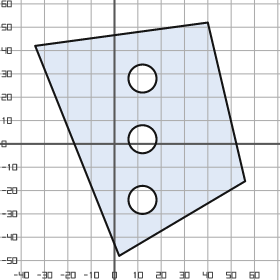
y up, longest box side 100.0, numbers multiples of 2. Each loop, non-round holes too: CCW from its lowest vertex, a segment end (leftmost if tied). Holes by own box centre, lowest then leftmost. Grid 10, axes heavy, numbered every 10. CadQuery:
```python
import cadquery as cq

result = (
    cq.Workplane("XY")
    .moveTo(2.0, -48.0)
    .lineTo(56.0, -16.0)
    .lineTo(40.0, 52.0)
    .lineTo(-34.0, 42.0)
    .close()
    .moveTo(12.0, -24.0)
    .circle(6.0)
    .moveTo(12.0, 2.0)
    .circle(6.0)
    .moveTo(12.0, 28.0)
    .circle(6.0)
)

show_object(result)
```